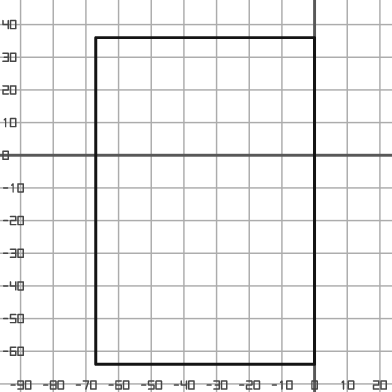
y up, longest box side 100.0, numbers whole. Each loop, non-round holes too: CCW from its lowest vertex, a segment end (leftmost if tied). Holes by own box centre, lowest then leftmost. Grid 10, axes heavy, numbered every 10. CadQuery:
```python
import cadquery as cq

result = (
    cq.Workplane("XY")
    .moveTo(-67.0, -64.0)
    .lineTo(0.0, -64.0)
    .lineTo(0.0, 36.0)
    .lineTo(-67.0, 36.0)
    .close()
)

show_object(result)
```